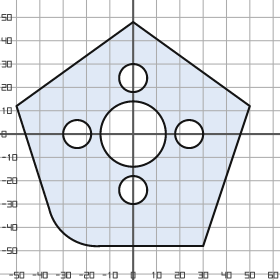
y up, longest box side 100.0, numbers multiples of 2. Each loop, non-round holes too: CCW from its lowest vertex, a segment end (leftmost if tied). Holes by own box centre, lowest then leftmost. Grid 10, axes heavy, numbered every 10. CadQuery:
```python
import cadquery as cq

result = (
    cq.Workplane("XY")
    .moveTo(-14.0, -48.0)
    .lineTo(30.0, -48.0)
    .lineTo(50.0, 12.0)
    .lineTo(0.0, 48.0)
    .lineTo(-50.0, 12.0)
    .lineTo(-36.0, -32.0)
    .threePointArc((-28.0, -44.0), (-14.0, -48.0))
    .close()
    .moveTo(0.0, -24.0)
    .circle(6.0)
    .moveTo(-24.0, 0.0)
    .circle(6.0)
    .moveTo(0.0, 0.0)
    .circle(14.0)
    .moveTo(24.0, 0.0)
    .circle(6.0)
    .moveTo(0.0, 24.0)
    .circle(6.0)
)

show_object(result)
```